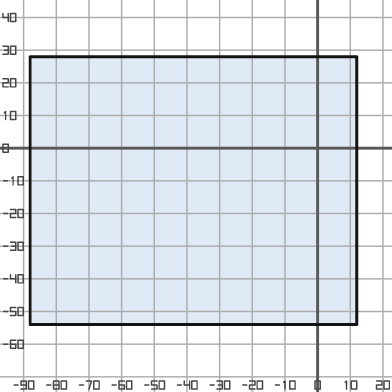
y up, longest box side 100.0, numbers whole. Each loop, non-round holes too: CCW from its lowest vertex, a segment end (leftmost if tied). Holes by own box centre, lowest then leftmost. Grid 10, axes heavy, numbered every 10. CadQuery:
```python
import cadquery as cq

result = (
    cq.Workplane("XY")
    .moveTo(-88.0, -54.0)
    .lineTo(12.0, -54.0)
    .lineTo(12.0, 28.0)
    .lineTo(-88.0, 28.0)
    .close()
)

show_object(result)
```